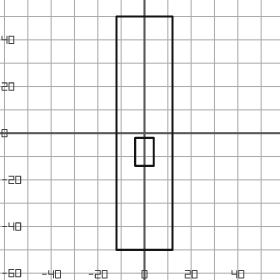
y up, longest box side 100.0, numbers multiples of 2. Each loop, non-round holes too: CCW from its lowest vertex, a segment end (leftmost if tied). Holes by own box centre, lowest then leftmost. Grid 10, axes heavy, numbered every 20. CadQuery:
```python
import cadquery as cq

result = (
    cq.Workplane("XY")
    .moveTo(-12.0, -50.0)
    .lineTo(12.0, -50.0)
    .lineTo(12.0, 50.0)
    .lineTo(-12.0, 50.0)
    .close()
    .moveTo(-4.0, -14.0)
    .lineTo(4.0, -14.0)
    .lineTo(4.0, -2.0)
    .lineTo(-4.0, -2.0)
    .close()
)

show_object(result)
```